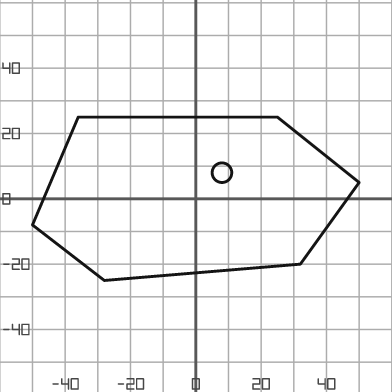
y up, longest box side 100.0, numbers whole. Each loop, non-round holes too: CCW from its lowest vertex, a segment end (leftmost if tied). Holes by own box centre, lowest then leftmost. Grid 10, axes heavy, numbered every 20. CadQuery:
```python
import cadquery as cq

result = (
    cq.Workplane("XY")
    .moveTo(-28.0, -25.0)
    .lineTo(32.0, -20.0)
    .lineTo(50.0, 5.0)
    .lineTo(25.0, 25.0)
    .lineTo(-36.0, 25.0)
    .lineTo(-50.0, -8.0)
    .close()
    .moveTo(8.0, 8.0)
    .circle(3.0)
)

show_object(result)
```